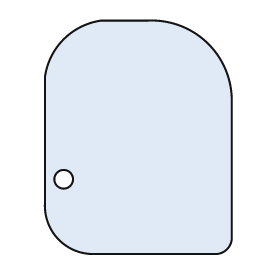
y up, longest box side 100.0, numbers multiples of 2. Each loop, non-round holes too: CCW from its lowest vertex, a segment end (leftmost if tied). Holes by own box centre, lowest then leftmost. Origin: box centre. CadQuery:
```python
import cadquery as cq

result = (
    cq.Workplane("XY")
    .moveTo(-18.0, -50.0)
    .lineTo(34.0, -50.0)
    .threePointArc((38.0, -48.0), (40.0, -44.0))
    .lineTo(40.0, 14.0)
    .threePointArc((30.0, 40.0), (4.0, 50.0))
    .lineTo(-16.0, 50.0)
    .threePointArc((-32.0, 42.0), (-40.0, 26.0))
    .lineTo(-40.0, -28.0)
    .threePointArc((-34.0, -44.0), (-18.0, -50.0))
    .close()
    .moveTo(-32.0, -18.0)
    .circle(4.0)
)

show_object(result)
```